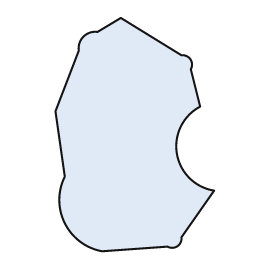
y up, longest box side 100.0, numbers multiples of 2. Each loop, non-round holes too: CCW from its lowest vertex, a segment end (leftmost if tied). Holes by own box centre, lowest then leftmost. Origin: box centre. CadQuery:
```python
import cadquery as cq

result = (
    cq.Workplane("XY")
    .moveTo(-14.0, -50.0)
    .lineTo(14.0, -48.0)
    .threePointArc((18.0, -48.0), (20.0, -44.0))
    .lineTo(34.0, -24.0)
    .threePointArc((18.0, -8.0), (28.0, 12.0))
    .lineTo(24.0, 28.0)
    .threePointArc((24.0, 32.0), (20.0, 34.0))
    .lineTo(-6.0, 50.0)
    .lineTo(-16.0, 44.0)
    .threePointArc((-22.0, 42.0), (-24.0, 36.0))
    .lineTo(-34.0, 10.0)
    .lineTo(-30.0, -18.0)
    .threePointArc((-30.0, -38.0), (-14.0, -50.0))
    .close()
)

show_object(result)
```